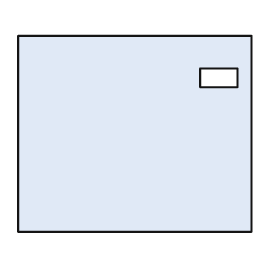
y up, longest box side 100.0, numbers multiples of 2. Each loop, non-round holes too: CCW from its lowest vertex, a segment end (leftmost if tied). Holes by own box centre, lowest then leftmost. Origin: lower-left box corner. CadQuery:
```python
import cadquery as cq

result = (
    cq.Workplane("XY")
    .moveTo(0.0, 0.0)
    .lineTo(100.0, 0.0)
    .lineTo(100.0, 84.0)
    .lineTo(0.0, 84.0)
    .close()
    .moveTo(78.0, 62.0)
    .lineTo(94.0, 62.0)
    .lineTo(94.0, 70.0)
    .lineTo(78.0, 70.0)
    .close()
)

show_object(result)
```